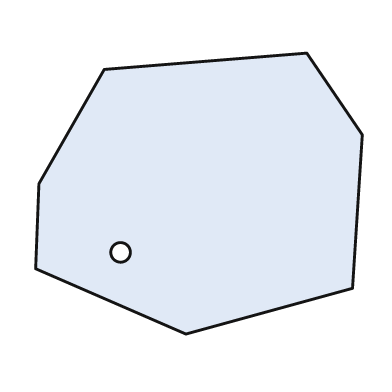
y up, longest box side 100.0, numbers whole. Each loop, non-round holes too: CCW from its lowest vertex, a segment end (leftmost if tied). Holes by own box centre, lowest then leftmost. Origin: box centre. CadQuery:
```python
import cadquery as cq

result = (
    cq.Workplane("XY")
    .moveTo(-4.0, -43.0)
    .lineTo(47.0, -29.0)
    .lineTo(50.0, 18.0)
    .lineTo(33.0, 43.0)
    .lineTo(-29.0, 38.0)
    .lineTo(-49.0, 3.0)
    .lineTo(-50.0, -23.0)
    .close()
    .moveTo(-24.0, -18.0)
    .circle(3.0)
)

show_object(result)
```